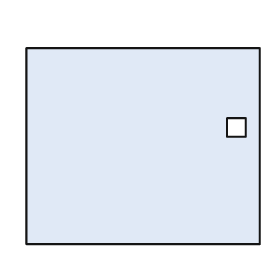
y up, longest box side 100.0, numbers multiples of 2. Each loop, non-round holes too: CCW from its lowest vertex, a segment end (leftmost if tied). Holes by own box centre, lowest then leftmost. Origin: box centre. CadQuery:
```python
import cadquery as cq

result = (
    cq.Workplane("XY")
    .moveTo(-50.0, -42.0)
    .lineTo(50.0, -42.0)
    .lineTo(50.0, 42.0)
    .lineTo(-50.0, 42.0)
    .close()
    .moveTo(36.0, 4.0)
    .lineTo(44.0, 4.0)
    .lineTo(44.0, 12.0)
    .lineTo(36.0, 12.0)
    .close()
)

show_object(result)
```